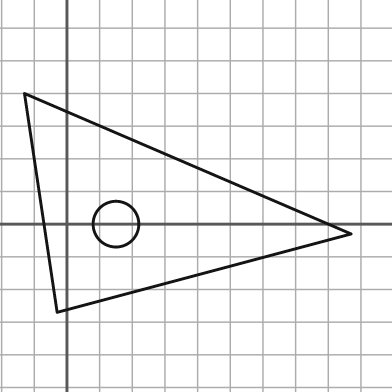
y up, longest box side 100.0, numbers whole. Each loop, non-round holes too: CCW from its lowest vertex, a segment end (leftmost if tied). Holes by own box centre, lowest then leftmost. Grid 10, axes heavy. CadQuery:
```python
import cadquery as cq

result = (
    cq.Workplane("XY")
    .moveTo(-3.0, -27.0)
    .lineTo(87.0, -3.0)
    .lineTo(-13.0, 40.0)
    .close()
    .moveTo(15.0, 0.0)
    .circle(7.0)
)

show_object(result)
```